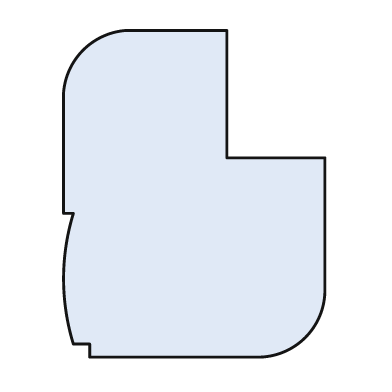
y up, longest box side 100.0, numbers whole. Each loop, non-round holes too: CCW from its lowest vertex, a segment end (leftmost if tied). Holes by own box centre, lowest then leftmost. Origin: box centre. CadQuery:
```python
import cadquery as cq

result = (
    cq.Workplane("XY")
    .moveTo(-32.0, -50.0)
    .lineTo(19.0, -50.0)
    .threePointArc((34.0, -44.0), (40.0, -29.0))
    .lineTo(40.0, 11.0)
    .lineTo(10.0, 11.0)
    .lineTo(10.0, 50.0)
    .lineTo(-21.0, 50.0)
    .threePointArc((-34.0, 44.0), (-40.0, 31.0))
    .lineTo(-40.0, -6.0)
    .lineTo(-37.0, -6.0)
    .threePointArc((-40.0, -26.0), (-37.0, -46.0))
    .lineTo(-32.0, -46.0)
    .close()
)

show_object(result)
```